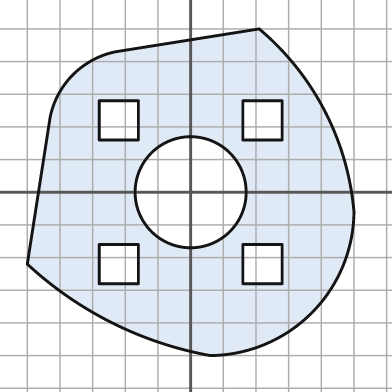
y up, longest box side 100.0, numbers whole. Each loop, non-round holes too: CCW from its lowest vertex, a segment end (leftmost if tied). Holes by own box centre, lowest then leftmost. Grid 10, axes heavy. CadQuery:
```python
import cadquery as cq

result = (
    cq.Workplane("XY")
    .moveTo(6.0, -50.0)
    .threePointArc((37.0, -37.0), (50.0, -6.0))
    .threePointArc((41.0, 25.0), (21.0, 50.0))
    .lineTo(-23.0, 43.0)
    .threePointArc((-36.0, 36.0), (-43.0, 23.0))
    .lineTo(-50.0, -22.0)
    .threePointArc((-24.0, -40.0), (6.0, -50.0))
    .close()
    .moveTo(-28.0, -28.0)
    .lineTo(-16.0, -28.0)
    .lineTo(-16.0, -16.0)
    .lineTo(-28.0, -16.0)
    .close()
    .moveTo(16.0, -28.0)
    .lineTo(28.0, -28.0)
    .lineTo(28.0, -16.0)
    .lineTo(16.0, -16.0)
    .close()
    .moveTo(0.0, 0.0)
    .circle(17.0)
    .moveTo(-28.0, 16.0)
    .lineTo(-16.0, 16.0)
    .lineTo(-16.0, 28.0)
    .lineTo(-28.0, 28.0)
    .close()
    .moveTo(16.0, 16.0)
    .lineTo(28.0, 16.0)
    .lineTo(28.0, 28.0)
    .lineTo(16.0, 28.0)
    .close()
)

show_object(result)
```